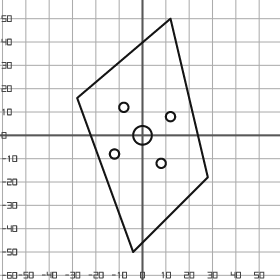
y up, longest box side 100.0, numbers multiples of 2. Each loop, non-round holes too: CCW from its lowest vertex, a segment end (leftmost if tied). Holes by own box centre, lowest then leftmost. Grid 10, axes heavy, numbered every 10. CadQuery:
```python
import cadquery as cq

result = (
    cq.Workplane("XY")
    .moveTo(-4.0, -50.0)
    .lineTo(28.0, -18.0)
    .lineTo(12.0, 50.0)
    .lineTo(-28.0, 16.0)
    .close()
    .moveTo(8.0, -12.0)
    .circle(2.0)
    .moveTo(-12.0, -8.0)
    .circle(2.0)
    .moveTo(0.0, 0.0)
    .circle(4.0)
    .moveTo(12.0, 8.0)
    .circle(2.0)
    .moveTo(-8.0, 12.0)
    .circle(2.0)
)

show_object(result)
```